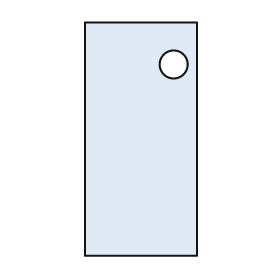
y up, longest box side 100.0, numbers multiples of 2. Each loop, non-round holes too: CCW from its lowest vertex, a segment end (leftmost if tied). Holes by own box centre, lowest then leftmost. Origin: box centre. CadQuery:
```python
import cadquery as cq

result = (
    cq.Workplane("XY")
    .moveTo(-24.0, -50.0)
    .lineTo(24.0, -50.0)
    .lineTo(24.0, 50.0)
    .lineTo(-24.0, 50.0)
    .close()
    .moveTo(14.0, 32.0)
    .circle(6.0)
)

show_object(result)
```